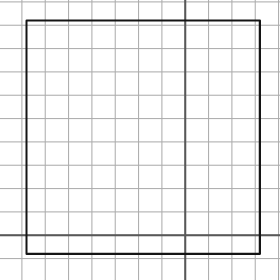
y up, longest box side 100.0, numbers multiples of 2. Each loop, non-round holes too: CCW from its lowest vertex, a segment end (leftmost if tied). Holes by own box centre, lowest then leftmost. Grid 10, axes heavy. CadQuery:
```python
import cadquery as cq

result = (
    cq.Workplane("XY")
    .moveTo(-68.0, -8.0)
    .lineTo(32.0, -8.0)
    .lineTo(32.0, 92.0)
    .lineTo(-68.0, 92.0)
    .close()
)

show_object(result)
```